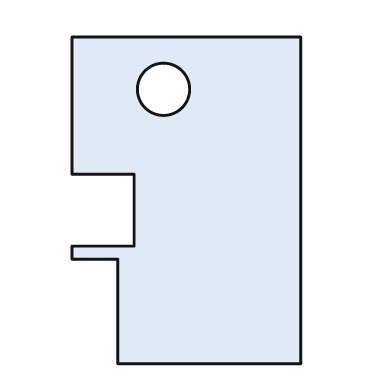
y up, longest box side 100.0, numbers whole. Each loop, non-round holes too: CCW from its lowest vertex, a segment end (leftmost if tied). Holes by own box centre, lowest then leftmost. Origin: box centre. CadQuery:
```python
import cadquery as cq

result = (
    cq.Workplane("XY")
    .moveTo(-21.0, -50.0)
    .lineTo(35.0, -50.0)
    .lineTo(35.0, 50.0)
    .lineTo(-35.0, 50.0)
    .lineTo(-35.0, 8.0)
    .lineTo(-16.0, 8.0)
    .lineTo(-16.0, -14.0)
    .lineTo(-35.0, -14.0)
    .lineTo(-35.0, -18.0)
    .lineTo(-21.0, -18.0)
    .close()
    .moveTo(-7.0, 34.0)
    .circle(8.0)
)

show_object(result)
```